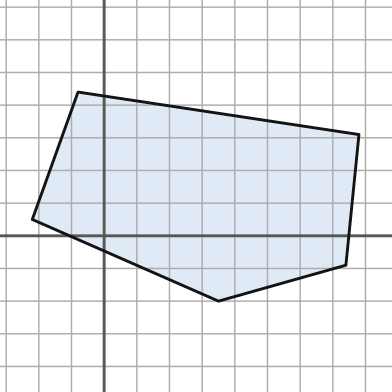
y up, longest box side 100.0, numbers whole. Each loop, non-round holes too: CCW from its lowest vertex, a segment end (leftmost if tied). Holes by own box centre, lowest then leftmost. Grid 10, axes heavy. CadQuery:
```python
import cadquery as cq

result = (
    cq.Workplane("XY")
    .moveTo(35.0, -20.0)
    .lineTo(74.0, -9.0)
    .lineTo(78.0, 31.0)
    .lineTo(-8.0, 44.0)
    .lineTo(-22.0, 5.0)
    .close()
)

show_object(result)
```